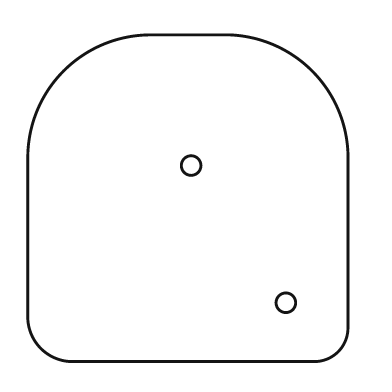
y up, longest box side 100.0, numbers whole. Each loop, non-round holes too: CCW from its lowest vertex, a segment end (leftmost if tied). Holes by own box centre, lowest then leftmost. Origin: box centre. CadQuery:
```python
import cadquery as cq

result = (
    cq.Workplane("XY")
    .moveTo(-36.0, -50.0)
    .lineTo(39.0, -50.0)
    .threePointArc((46.0, -47.0), (49.0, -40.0))
    .lineTo(49.0, 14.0)
    .threePointArc((38.0, 39.0), (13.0, 50.0))
    .lineTo(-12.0, 50.0)
    .threePointArc((-38.0, 39.0), (-49.0, 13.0))
    .lineTo(-49.0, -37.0)
    .threePointArc((-45.0, -46.0), (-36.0, -50.0))
    .close()
    .moveTo(30.0, -32.0)
    .circle(3.0)
    .moveTo(1.0, 10.0)
    .circle(3.0)
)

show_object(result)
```